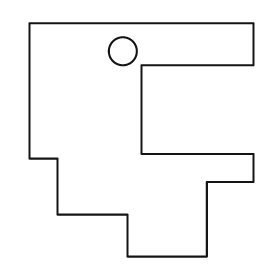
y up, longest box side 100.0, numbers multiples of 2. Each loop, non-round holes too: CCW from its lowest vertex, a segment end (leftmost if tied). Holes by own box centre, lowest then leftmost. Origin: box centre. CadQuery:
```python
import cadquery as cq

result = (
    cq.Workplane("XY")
    .moveTo(-6.0, -50.0)
    .lineTo(28.0, -50.0)
    .lineTo(28.0, -18.0)
    .lineTo(48.0, -18.0)
    .lineTo(48.0, -6.0)
    .lineTo(0.0, -6.0)
    .lineTo(0.0, 32.0)
    .lineTo(48.0, 32.0)
    .lineTo(48.0, 50.0)
    .lineTo(-48.0, 50.0)
    .lineTo(-48.0, -8.0)
    .lineTo(-36.0, -8.0)
    .lineTo(-36.0, -32.0)
    .lineTo(-6.0, -32.0)
    .close()
    .moveTo(-8.0, 38.0)
    .circle(6.0)
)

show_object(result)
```